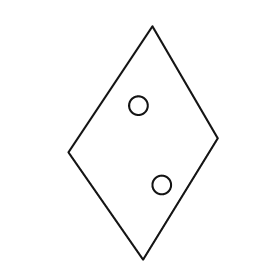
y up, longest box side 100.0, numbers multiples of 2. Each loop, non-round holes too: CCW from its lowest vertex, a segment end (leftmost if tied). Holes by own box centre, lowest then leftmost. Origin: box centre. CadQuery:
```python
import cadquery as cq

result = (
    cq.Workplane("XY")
    .moveTo(0.0, -50.0)
    .lineTo(32.0, 2.0)
    .lineTo(4.0, 50.0)
    .lineTo(-32.0, -4.0)
    .close()
    .moveTo(8.0, -18.0)
    .circle(4.0)
    .moveTo(-2.0, 16.0)
    .circle(4.0)
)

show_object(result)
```